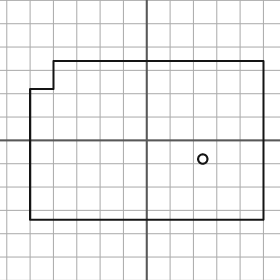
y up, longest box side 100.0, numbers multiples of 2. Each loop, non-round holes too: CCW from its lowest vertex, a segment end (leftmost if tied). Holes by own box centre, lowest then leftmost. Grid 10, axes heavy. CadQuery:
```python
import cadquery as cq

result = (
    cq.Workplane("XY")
    .moveTo(-50.0, -34.0)
    .lineTo(50.0, -34.0)
    .lineTo(50.0, 34.0)
    .lineTo(-40.0, 34.0)
    .lineTo(-40.0, 22.0)
    .lineTo(-50.0, 22.0)
    .close()
    .moveTo(24.0, -8.0)
    .circle(2.0)
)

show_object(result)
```